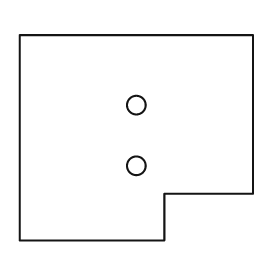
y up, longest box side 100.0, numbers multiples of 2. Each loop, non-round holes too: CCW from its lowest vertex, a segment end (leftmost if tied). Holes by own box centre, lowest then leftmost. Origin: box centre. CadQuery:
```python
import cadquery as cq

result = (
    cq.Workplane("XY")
    .moveTo(-50.0, -44.0)
    .lineTo(12.0, -44.0)
    .lineTo(12.0, -24.0)
    .lineTo(50.0, -24.0)
    .lineTo(50.0, 44.0)
    .lineTo(-50.0, 44.0)
    .close()
    .moveTo(0.0, -12.0)
    .circle(4.0)
    .moveTo(0.0, 14.0)
    .circle(4.0)
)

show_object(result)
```